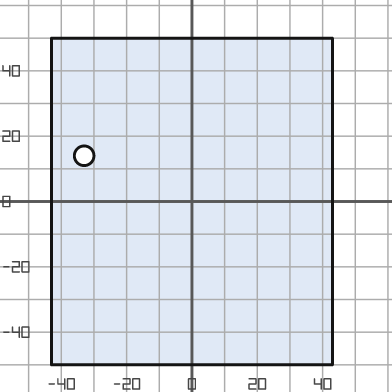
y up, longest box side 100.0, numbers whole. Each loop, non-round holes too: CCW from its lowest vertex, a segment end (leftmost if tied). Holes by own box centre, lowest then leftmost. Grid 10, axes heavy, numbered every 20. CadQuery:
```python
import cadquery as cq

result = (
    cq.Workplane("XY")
    .moveTo(-43.0, -50.0)
    .lineTo(43.0, -50.0)
    .lineTo(43.0, 50.0)
    .lineTo(-43.0, 50.0)
    .close()
    .moveTo(-33.0, 14.0)
    .circle(3.0)
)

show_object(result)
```